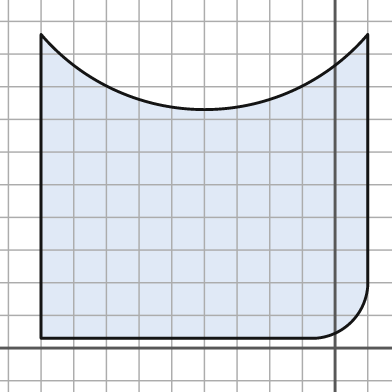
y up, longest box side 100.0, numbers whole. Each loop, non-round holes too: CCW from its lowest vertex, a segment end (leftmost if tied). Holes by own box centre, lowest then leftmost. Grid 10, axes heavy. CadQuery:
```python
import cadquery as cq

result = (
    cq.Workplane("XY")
    .moveTo(-90.0, 3.0)
    .lineTo(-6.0, 3.0)
    .threePointArc((5.0, 8.0), (10.0, 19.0))
    .lineTo(10.0, 96.0)
    .threePointArc((-40.0, 73.0), (-90.0, 96.0))
    .close()
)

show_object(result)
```